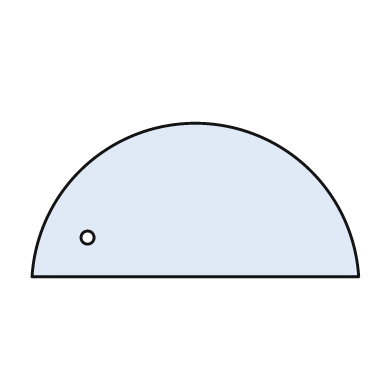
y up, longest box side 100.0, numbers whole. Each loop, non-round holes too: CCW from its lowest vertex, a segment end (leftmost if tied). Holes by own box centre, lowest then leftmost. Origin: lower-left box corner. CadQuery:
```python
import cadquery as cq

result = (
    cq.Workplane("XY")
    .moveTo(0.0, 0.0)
    .lineTo(100.0, 0.0)
    .threePointArc((50.0, 47.0), (0.0, 0.0))
    .close()
    .moveTo(17.0, 12.0)
    .circle(2.0)
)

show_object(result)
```